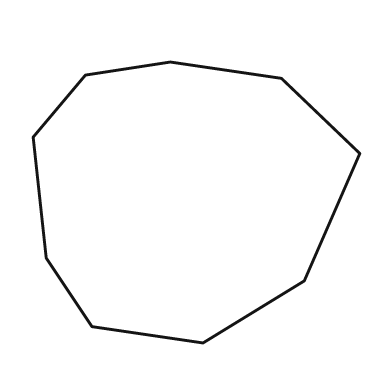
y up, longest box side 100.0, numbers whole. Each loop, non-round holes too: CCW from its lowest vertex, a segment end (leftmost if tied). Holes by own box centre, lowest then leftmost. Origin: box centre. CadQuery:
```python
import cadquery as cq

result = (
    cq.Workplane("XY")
    .moveTo(2.0, -43.0)
    .lineTo(33.0, -24.0)
    .lineTo(50.0, 15.0)
    .lineTo(26.0, 38.0)
    .lineTo(-8.0, 43.0)
    .lineTo(-34.0, 39.0)
    .lineTo(-50.0, 20.0)
    .lineTo(-46.0, -17.0)
    .lineTo(-32.0, -38.0)
    .close()
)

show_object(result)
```